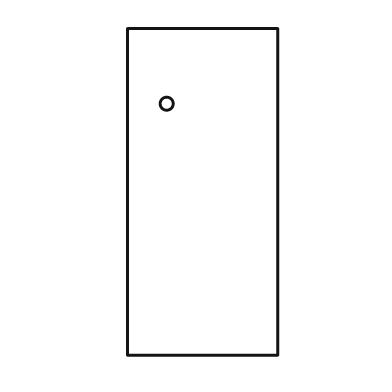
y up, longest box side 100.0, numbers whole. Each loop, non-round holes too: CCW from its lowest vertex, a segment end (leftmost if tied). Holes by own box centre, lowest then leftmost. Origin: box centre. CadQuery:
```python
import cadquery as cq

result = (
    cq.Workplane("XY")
    .moveTo(-23.0, -50.0)
    .lineTo(23.0, -50.0)
    .lineTo(23.0, 50.0)
    .lineTo(-23.0, 50.0)
    .close()
    .moveTo(-11.0, 27.0)
    .circle(2.0)
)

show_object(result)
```